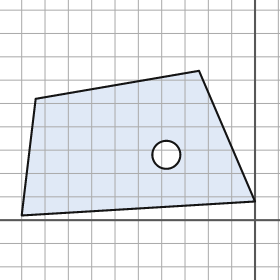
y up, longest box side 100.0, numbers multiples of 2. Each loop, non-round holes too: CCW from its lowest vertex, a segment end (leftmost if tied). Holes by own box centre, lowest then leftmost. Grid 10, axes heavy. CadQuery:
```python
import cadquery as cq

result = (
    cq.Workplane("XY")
    .moveTo(-100.0, 2.0)
    .lineTo(0.0, 8.0)
    .lineTo(-24.0, 64.0)
    .lineTo(-94.0, 52.0)
    .close()
    .moveTo(-38.0, 28.0)
    .circle(6.0)
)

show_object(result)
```